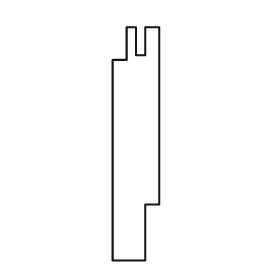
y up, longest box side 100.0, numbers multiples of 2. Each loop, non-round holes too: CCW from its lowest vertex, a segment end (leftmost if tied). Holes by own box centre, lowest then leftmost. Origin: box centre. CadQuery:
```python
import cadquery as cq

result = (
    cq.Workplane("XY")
    .moveTo(-10.0, -50.0)
    .lineTo(4.0, -50.0)
    .lineTo(4.0, -26.0)
    .lineTo(10.0, -26.0)
    .lineTo(10.0, 50.0)
    .lineTo(4.0, 50.0)
    .lineTo(4.0, 38.0)
    .lineTo(0.0, 38.0)
    .lineTo(0.0, 50.0)
    .lineTo(-4.0, 50.0)
    .lineTo(-4.0, 36.0)
    .lineTo(-10.0, 36.0)
    .close()
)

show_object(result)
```